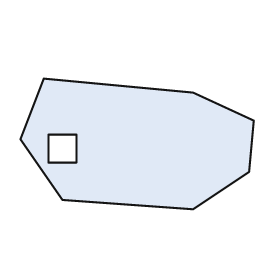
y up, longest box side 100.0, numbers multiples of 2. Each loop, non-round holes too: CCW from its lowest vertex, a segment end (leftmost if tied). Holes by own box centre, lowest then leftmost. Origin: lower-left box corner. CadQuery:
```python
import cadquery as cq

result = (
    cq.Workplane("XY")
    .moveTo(74.0, 0.0)
    .lineTo(98.0, 16.0)
    .lineTo(100.0, 38.0)
    .lineTo(74.0, 50.0)
    .lineTo(10.0, 56.0)
    .lineTo(0.0, 30.0)
    .lineTo(18.0, 4.0)
    .close()
    .moveTo(12.0, 20.0)
    .lineTo(24.0, 20.0)
    .lineTo(24.0, 32.0)
    .lineTo(12.0, 32.0)
    .close()
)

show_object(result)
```